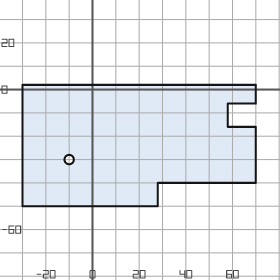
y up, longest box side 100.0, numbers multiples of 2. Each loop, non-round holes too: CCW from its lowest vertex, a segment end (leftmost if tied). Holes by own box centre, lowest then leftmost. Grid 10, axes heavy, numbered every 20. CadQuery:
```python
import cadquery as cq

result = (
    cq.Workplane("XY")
    .moveTo(-30.0, -50.0)
    .lineTo(28.0, -50.0)
    .lineTo(28.0, -40.0)
    .lineTo(70.0, -40.0)
    .lineTo(70.0, -16.0)
    .lineTo(58.0, -16.0)
    .lineTo(58.0, -6.0)
    .lineTo(70.0, -6.0)
    .lineTo(70.0, 2.0)
    .lineTo(-30.0, 2.0)
    .close()
    .moveTo(-10.0, -30.0)
    .circle(2.0)
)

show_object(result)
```